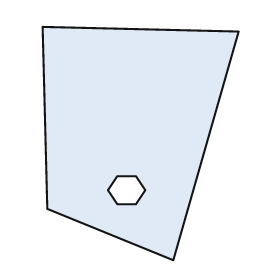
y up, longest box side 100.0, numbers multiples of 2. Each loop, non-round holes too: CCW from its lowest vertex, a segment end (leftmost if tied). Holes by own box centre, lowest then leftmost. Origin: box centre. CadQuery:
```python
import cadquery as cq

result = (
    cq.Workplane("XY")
    .moveTo(14.0, -50.0)
    .lineTo(42.0, 48.0)
    .lineTo(-42.0, 50.0)
    .lineTo(-40.0, -28.0)
    .close()
    .moveTo(-10.0, -26.0)
    .lineTo(-2.0, -26.0)
    .lineTo(2.0, -20.0)
    .lineTo(-2.0, -14.0)
    .lineTo(-10.0, -14.0)
    .lineTo(-14.0, -20.0)
    .close()
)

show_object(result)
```